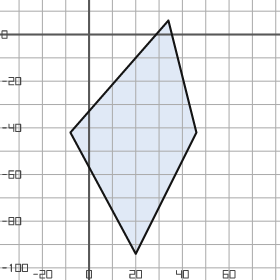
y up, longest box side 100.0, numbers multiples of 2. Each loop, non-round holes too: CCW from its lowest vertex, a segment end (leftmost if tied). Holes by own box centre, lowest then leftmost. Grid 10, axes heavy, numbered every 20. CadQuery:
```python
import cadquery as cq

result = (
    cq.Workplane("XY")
    .moveTo(20.0, -94.0)
    .lineTo(46.0, -42.0)
    .lineTo(34.0, 6.0)
    .lineTo(-8.0, -42.0)
    .close()
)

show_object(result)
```